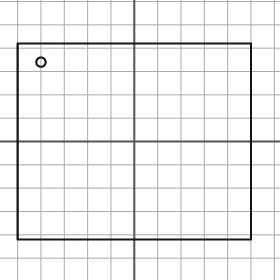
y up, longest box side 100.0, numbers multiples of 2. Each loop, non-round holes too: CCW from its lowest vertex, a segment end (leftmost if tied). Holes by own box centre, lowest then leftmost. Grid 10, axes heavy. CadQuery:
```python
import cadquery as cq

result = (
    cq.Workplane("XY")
    .moveTo(-50.0, -42.0)
    .lineTo(50.0, -42.0)
    .lineTo(50.0, 42.0)
    .lineTo(-50.0, 42.0)
    .close()
    .moveTo(-40.0, 34.0)
    .circle(2.0)
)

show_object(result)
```